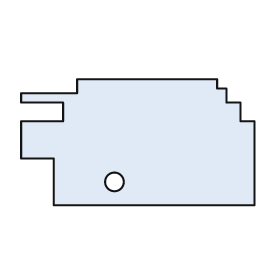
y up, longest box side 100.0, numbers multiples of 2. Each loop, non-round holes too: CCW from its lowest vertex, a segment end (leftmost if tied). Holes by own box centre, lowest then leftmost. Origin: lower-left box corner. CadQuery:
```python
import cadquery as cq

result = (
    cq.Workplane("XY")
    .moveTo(14.0, 0.0)
    .lineTo(100.0, 0.0)
    .lineTo(100.0, 36.0)
    .lineTo(94.0, 36.0)
    .lineTo(94.0, 44.0)
    .lineTo(88.0, 44.0)
    .lineTo(88.0, 50.0)
    .lineTo(84.0, 50.0)
    .lineTo(84.0, 54.0)
    .lineTo(24.0, 54.0)
    .lineTo(24.0, 48.0)
    .lineTo(0.0, 48.0)
    .lineTo(0.0, 44.0)
    .lineTo(18.0, 44.0)
    .lineTo(18.0, 36.0)
    .lineTo(0.0, 36.0)
    .lineTo(0.0, 20.0)
    .lineTo(14.0, 20.0)
    .close()
    .moveTo(40.0, 10.0)
    .circle(4.0)
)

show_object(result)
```